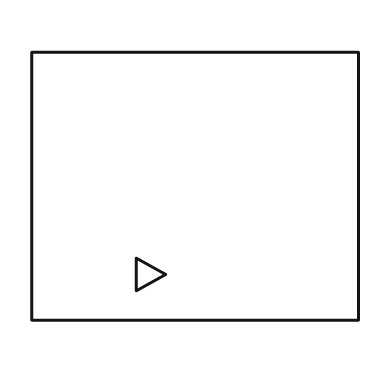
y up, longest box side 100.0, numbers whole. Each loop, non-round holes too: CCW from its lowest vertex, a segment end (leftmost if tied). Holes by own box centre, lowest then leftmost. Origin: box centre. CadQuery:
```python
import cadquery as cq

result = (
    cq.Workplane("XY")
    .moveTo(-50.0, -41.0)
    .lineTo(50.0, -41.0)
    .lineTo(50.0, 41.0)
    .lineTo(-50.0, 41.0)
    .close()
    .moveTo(-18.0, -32.0)
    .lineTo(-9.0, -27.0)
    .lineTo(-18.0, -22.0)
    .close()
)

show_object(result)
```